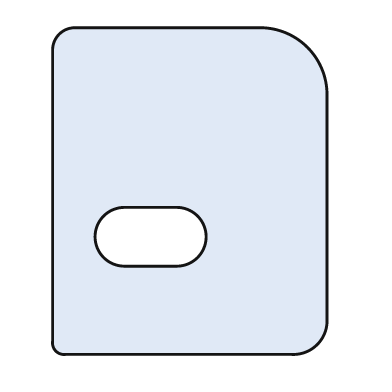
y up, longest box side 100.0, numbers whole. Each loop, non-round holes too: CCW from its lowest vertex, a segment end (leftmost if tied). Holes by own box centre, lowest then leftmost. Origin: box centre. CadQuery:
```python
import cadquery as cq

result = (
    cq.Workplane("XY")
    .moveTo(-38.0, -50.0)
    .lineTo(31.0, -50.0)
    .threePointArc((39.0, -47.0), (42.0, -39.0))
    .lineTo(42.0, 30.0)
    .threePointArc((36.0, 44.0), (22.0, 50.0))
    .lineTo(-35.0, 50.0)
    .threePointArc((-40.0, 48.0), (-42.0, 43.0))
    .lineTo(-42.0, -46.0)
    .threePointArc((-41.0, -49.0), (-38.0, -50.0))
    .close()
    .moveTo(-20.0, -23.0)
    .lineTo(-4.0, -23.0)
    .threePointArc((5.0, -14.0), (-4.0, -5.0))
    .lineTo(-20.0, -5.0)
    .threePointArc((-29.0, -14.0), (-20.0, -23.0))
    .close()
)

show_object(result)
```